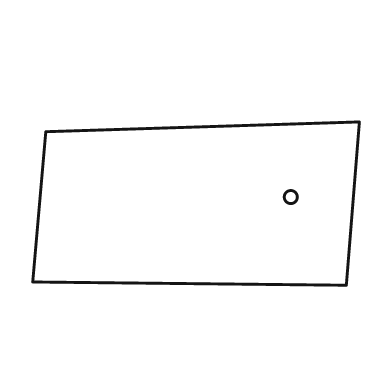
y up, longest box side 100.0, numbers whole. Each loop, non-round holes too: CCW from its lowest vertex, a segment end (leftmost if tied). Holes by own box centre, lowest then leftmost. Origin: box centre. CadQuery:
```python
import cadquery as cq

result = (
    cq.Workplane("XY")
    .moveTo(46.0, -25.0)
    .lineTo(50.0, 25.0)
    .lineTo(-46.0, 22.0)
    .lineTo(-50.0, -24.0)
    .close()
    .moveTo(29.0, 2.0)
    .circle(2.0)
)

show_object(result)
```